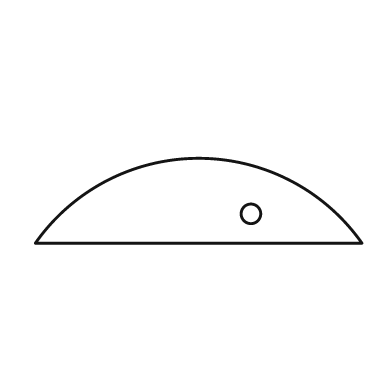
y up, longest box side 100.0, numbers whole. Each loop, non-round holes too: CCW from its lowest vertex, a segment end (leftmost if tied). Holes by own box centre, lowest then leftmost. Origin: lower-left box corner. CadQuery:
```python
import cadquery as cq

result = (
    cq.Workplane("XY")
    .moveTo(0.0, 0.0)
    .lineTo(100.0, 0.0)
    .threePointArc((50.0, 26.0), (0.0, 0.0))
    .close()
    .moveTo(66.0, 9.0)
    .circle(3.0)
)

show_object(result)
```